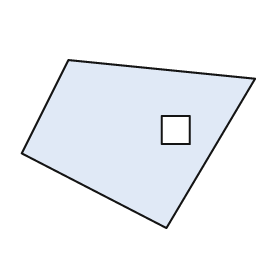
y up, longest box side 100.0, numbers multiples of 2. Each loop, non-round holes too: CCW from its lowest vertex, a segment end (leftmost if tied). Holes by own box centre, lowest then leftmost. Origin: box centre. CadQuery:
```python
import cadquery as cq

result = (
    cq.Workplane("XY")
    .moveTo(12.0, -36.0)
    .lineTo(50.0, 28.0)
    .lineTo(-30.0, 36.0)
    .lineTo(-50.0, -4.0)
    .close()
    .moveTo(10.0, 0.0)
    .lineTo(22.0, 0.0)
    .lineTo(22.0, 12.0)
    .lineTo(10.0, 12.0)
    .close()
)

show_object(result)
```